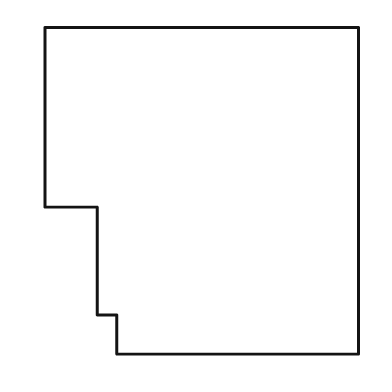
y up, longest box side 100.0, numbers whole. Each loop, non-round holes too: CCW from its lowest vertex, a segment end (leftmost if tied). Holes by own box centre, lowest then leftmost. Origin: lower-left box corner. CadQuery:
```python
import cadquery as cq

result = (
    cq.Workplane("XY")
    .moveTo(22.0, 0.0)
    .lineTo(96.0, 0.0)
    .lineTo(96.0, 100.0)
    .lineTo(0.0, 100.0)
    .lineTo(0.0, 45.0)
    .lineTo(16.0, 45.0)
    .lineTo(16.0, 12.0)
    .lineTo(22.0, 12.0)
    .close()
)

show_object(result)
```